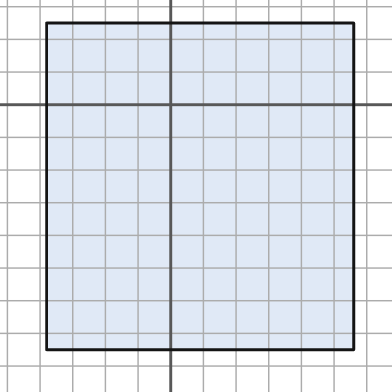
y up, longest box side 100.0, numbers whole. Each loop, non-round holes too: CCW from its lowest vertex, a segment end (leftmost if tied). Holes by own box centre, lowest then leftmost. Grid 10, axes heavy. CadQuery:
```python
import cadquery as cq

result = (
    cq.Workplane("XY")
    .moveTo(-38.0, -75.0)
    .lineTo(56.0, -75.0)
    .lineTo(56.0, 25.0)
    .lineTo(-38.0, 25.0)
    .close()
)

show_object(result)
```